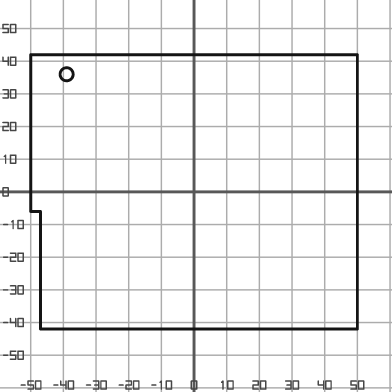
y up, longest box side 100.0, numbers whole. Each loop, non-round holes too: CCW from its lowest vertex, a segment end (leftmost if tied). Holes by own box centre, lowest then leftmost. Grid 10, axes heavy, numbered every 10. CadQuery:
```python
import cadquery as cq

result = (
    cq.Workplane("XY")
    .moveTo(-47.0, -42.0)
    .lineTo(50.0, -42.0)
    .lineTo(50.0, 42.0)
    .lineTo(-50.0, 42.0)
    .lineTo(-50.0, -6.0)
    .lineTo(-47.0, -6.0)
    .close()
    .moveTo(-39.0, 36.0)
    .circle(2.0)
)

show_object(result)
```